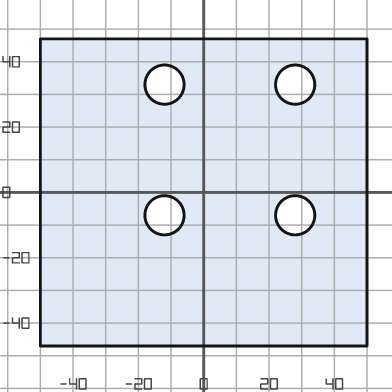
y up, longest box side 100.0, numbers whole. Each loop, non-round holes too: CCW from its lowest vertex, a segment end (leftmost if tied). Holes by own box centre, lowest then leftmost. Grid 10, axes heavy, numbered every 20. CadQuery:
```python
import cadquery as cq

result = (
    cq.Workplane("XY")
    .moveTo(-50.0, -47.0)
    .lineTo(50.0, -47.0)
    .lineTo(50.0, 47.0)
    .lineTo(-50.0, 47.0)
    .close()
    .moveTo(-12.0, -7.0)
    .circle(6.0)
    .moveTo(28.0, -7.0)
    .circle(6.0)
    .moveTo(-12.0, 33.0)
    .circle(6.0)
    .moveTo(28.0, 33.0)
    .circle(6.0)
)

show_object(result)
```